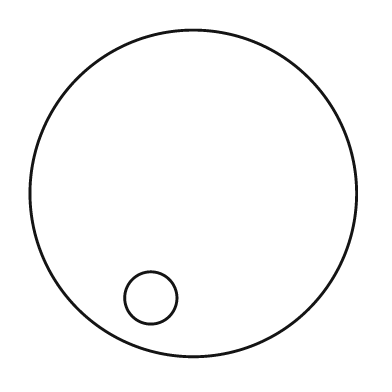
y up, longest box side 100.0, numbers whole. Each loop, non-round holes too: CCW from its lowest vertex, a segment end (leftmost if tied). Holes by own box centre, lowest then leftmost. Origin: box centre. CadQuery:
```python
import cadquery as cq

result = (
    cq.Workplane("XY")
    .moveTo(0.0, 0.0)
    .circle(50.0)
    .moveTo(-13.0, -32.0)
    .circle(8.0)
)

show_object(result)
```